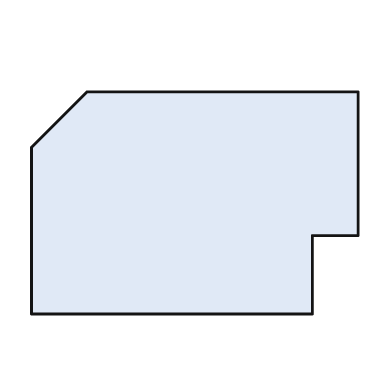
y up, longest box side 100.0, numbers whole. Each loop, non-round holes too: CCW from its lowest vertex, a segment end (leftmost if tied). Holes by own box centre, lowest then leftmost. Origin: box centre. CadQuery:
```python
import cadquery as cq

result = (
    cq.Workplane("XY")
    .moveTo(-50.0, -34.0)
    .lineTo(36.0, -34.0)
    .lineTo(36.0, -10.0)
    .lineTo(50.0, -10.0)
    .lineTo(50.0, 34.0)
    .lineTo(-33.0, 34.0)
    .lineTo(-50.0, 17.0)
    .close()
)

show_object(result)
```